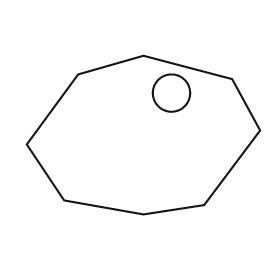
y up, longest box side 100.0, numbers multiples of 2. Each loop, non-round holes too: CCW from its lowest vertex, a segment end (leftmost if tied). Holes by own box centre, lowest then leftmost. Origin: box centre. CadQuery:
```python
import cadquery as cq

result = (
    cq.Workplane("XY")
    .moveTo(0.0, -34.0)
    .lineTo(26.0, -30.0)
    .lineTo(50.0, 2.0)
    .lineTo(38.0, 24.0)
    .lineTo(0.0, 34.0)
    .lineTo(-28.0, 26.0)
    .lineTo(-50.0, -4.0)
    .lineTo(-34.0, -28.0)
    .close()
    .moveTo(12.0, 18.0)
    .circle(8.0)
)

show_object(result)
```